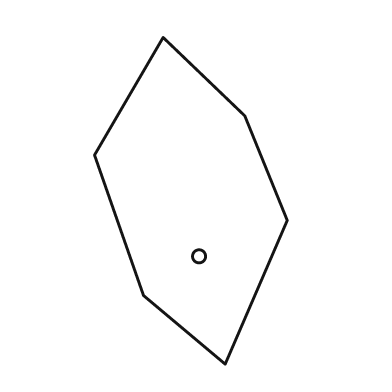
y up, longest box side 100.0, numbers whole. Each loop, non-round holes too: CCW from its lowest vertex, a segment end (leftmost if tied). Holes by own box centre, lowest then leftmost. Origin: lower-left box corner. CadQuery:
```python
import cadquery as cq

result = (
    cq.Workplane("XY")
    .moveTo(40.0, 0.0)
    .lineTo(59.0, 44.0)
    .lineTo(46.0, 76.0)
    .lineTo(21.0, 100.0)
    .lineTo(0.0, 64.0)
    .lineTo(15.0, 21.0)
    .close()
    .moveTo(32.0, 33.0)
    .circle(2.0)
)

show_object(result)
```